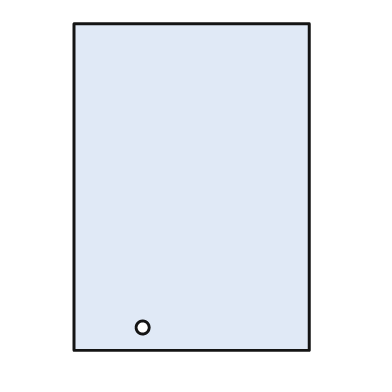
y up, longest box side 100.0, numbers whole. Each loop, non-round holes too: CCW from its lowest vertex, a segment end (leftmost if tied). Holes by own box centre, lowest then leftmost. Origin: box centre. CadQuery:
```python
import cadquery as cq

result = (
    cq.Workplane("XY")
    .moveTo(-36.0, -50.0)
    .lineTo(36.0, -50.0)
    .lineTo(36.0, 50.0)
    .lineTo(-36.0, 50.0)
    .close()
    .moveTo(-15.0, -43.0)
    .circle(2.0)
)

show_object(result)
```